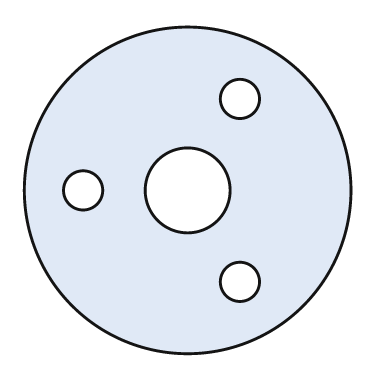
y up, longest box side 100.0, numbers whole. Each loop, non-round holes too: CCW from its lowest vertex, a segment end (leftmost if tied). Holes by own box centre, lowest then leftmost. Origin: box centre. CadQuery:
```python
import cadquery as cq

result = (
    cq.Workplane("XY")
    .moveTo(0.0, 0.0)
    .circle(50.0)
    .moveTo(16.0, -28.0)
    .circle(6.0)
    .moveTo(-32.0, 0.0)
    .circle(6.0)
    .moveTo(0.0, 0.0)
    .circle(13.0)
    .moveTo(16.0, 28.0)
    .circle(6.0)
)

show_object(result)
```